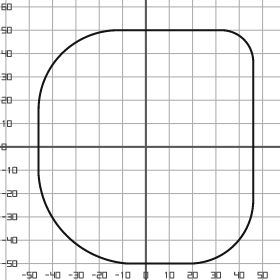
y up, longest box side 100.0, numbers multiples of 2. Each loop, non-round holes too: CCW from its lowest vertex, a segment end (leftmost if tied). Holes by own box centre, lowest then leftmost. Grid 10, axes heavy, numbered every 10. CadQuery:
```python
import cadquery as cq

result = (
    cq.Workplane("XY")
    .moveTo(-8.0, -50.0)
    .lineTo(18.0, -50.0)
    .threePointArc((38.0, -42.0), (46.0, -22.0))
    .lineTo(46.0, 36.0)
    .threePointArc((42.0, 46.0), (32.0, 50.0))
    .lineTo(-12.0, 50.0)
    .threePointArc((-36.0, 40.0), (-46.0, 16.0))
    .lineTo(-46.0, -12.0)
    .threePointArc((-34.0, -38.0), (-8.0, -50.0))
    .close()
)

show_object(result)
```